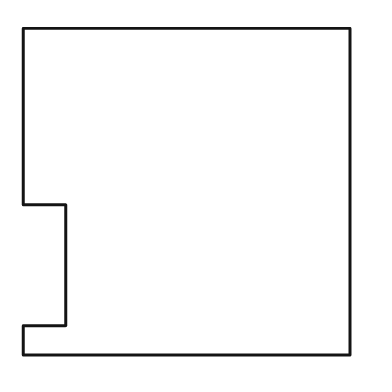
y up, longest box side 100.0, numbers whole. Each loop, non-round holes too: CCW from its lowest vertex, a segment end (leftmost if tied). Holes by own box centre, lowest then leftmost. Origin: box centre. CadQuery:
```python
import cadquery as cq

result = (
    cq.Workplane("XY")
    .moveTo(-50.0, -50.0)
    .lineTo(50.0, -50.0)
    .lineTo(50.0, 50.0)
    .lineTo(-50.0, 50.0)
    .lineTo(-50.0, -4.0)
    .lineTo(-37.0, -4.0)
    .lineTo(-37.0, -41.0)
    .lineTo(-50.0, -41.0)
    .close()
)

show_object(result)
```